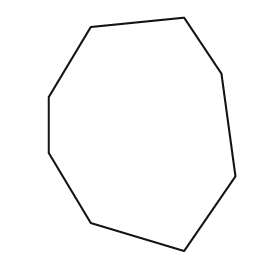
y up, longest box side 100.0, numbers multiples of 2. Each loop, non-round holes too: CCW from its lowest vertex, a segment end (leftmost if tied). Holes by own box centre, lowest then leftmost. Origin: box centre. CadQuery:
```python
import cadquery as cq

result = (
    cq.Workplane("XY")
    .moveTo(18.0, -50.0)
    .lineTo(40.0, -18.0)
    .lineTo(34.0, 26.0)
    .lineTo(18.0, 50.0)
    .lineTo(-22.0, 46.0)
    .lineTo(-40.0, 16.0)
    .lineTo(-40.0, -8.0)
    .lineTo(-22.0, -38.0)
    .close()
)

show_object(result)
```